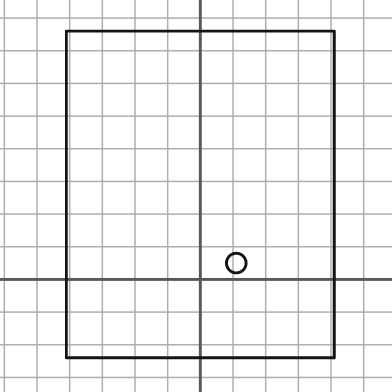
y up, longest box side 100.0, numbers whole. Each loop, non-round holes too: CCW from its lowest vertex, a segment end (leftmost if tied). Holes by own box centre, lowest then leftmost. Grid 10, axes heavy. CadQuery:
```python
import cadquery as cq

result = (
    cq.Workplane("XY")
    .moveTo(-41.0, -24.0)
    .lineTo(41.0, -24.0)
    .lineTo(41.0, 76.0)
    .lineTo(-41.0, 76.0)
    .close()
    .moveTo(11.0, 5.0)
    .circle(3.0)
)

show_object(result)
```